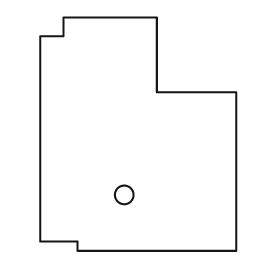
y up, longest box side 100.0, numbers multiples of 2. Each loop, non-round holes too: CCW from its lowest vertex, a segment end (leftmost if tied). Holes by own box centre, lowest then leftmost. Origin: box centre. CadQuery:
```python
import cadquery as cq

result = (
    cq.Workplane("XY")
    .moveTo(-26.0, -50.0)
    .lineTo(42.0, -50.0)
    .lineTo(42.0, 18.0)
    .lineTo(8.0, 18.0)
    .lineTo(8.0, 50.0)
    .lineTo(-32.0, 50.0)
    .lineTo(-32.0, 42.0)
    .lineTo(-42.0, 42.0)
    .lineTo(-42.0, -46.0)
    .lineTo(-26.0, -46.0)
    .close()
    .moveTo(-6.0, -26.0)
    .circle(4.0)
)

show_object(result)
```